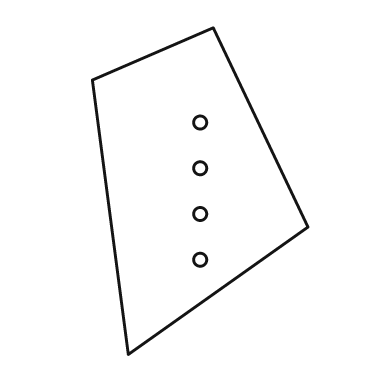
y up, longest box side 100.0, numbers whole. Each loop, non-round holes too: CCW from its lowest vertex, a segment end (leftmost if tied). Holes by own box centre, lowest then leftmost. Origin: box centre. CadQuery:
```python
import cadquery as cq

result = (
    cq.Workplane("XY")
    .moveTo(-22.0, -50.0)
    .lineTo(33.0, -11.0)
    .lineTo(4.0, 50.0)
    .lineTo(-33.0, 34.0)
    .close()
    .moveTo(0.0, -21.0)
    .circle(2.0)
    .moveTo(0.0, -7.0)
    .circle(2.0)
    .moveTo(0.0, 7.0)
    .circle(2.0)
    .moveTo(0.0, 21.0)
    .circle(2.0)
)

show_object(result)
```